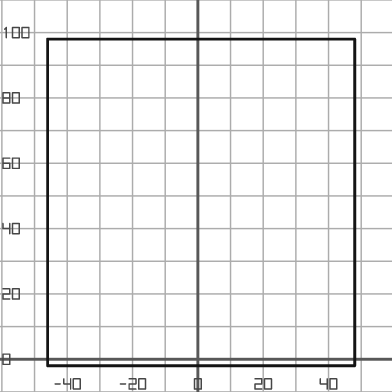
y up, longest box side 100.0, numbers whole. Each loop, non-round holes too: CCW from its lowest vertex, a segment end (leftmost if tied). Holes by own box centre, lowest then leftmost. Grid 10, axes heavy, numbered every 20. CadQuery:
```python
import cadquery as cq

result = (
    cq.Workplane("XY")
    .moveTo(-46.0, -2.0)
    .lineTo(48.0, -2.0)
    .lineTo(48.0, 98.0)
    .lineTo(-46.0, 98.0)
    .close()
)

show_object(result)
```